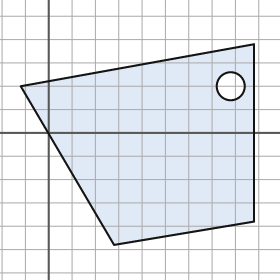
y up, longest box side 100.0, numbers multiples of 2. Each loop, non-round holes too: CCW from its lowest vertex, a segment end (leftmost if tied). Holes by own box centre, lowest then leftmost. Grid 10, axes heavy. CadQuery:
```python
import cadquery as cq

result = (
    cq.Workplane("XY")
    .moveTo(28.0, -48.0)
    .lineTo(88.0, -38.0)
    .lineTo(88.0, 38.0)
    .lineTo(-12.0, 20.0)
    .close()
    .moveTo(78.0, 20.0)
    .circle(6.0)
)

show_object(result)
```